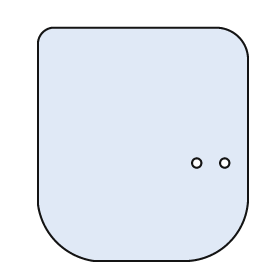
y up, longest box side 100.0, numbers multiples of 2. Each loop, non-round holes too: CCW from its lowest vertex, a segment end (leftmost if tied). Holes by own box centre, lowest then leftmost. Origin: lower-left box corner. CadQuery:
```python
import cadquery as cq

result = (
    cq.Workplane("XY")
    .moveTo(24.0, 0.0)
    .lineTo(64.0, 0.0)
    .threePointArc((82.0, 8.0), (90.0, 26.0))
    .lineTo(90.0, 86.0)
    .threePointArc((86.0, 96.0), (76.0, 100.0))
    .lineTo(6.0, 100.0)
    .threePointArc((2.0, 98.0), (0.0, 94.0))
    .lineTo(0.0, 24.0)
    .threePointArc((8.0, 8.0), (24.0, 0.0))
    .close()
    .moveTo(68.0, 42.0)
    .circle(2.0)
    .moveTo(80.0, 42.0)
    .circle(2.0)
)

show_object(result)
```